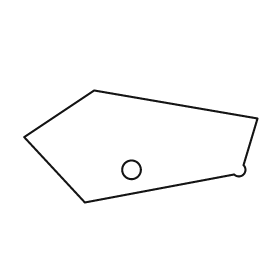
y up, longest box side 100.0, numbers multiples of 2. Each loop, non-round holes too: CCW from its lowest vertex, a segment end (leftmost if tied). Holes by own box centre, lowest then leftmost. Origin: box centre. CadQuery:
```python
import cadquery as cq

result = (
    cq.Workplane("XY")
    .moveTo(-24.0, -24.0)
    .lineTo(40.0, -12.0)
    .threePointArc((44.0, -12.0), (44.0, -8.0))
    .lineTo(50.0, 12.0)
    .lineTo(-20.0, 24.0)
    .lineTo(-50.0, 4.0)
    .close()
    .moveTo(-4.0, -10.0)
    .circle(4.0)
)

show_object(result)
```